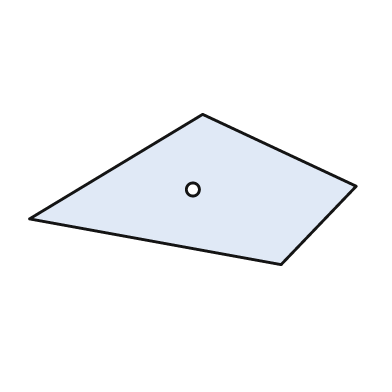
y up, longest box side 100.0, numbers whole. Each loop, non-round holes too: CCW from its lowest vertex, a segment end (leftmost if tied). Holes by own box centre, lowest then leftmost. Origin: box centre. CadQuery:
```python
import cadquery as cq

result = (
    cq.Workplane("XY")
    .moveTo(27.0, -23.0)
    .lineTo(50.0, 1.0)
    .lineTo(3.0, 23.0)
    .lineTo(-50.0, -9.0)
    .close()
    .moveTo(0.0, 0.0)
    .circle(2.0)
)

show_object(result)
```